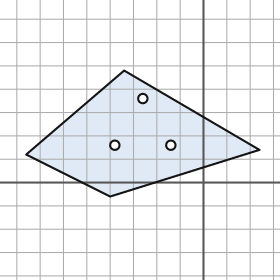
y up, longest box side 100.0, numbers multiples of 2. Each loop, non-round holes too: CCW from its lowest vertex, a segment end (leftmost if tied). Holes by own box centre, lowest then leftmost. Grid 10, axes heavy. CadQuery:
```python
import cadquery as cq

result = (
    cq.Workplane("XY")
    .moveTo(-40.0, -6.0)
    .lineTo(24.0, 14.0)
    .lineTo(-34.0, 48.0)
    .lineTo(-76.0, 12.0)
    .close()
    .moveTo(-38.0, 16.0)
    .circle(2.0)
    .moveTo(-14.0, 16.0)
    .circle(2.0)
    .moveTo(-26.0, 36.0)
    .circle(2.0)
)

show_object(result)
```